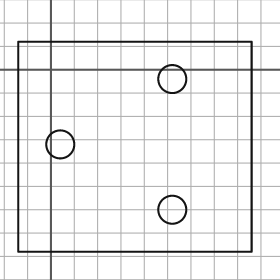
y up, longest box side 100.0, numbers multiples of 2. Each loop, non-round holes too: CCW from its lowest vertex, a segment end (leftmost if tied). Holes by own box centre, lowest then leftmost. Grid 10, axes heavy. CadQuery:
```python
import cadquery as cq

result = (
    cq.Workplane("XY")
    .moveTo(-14.0, -78.0)
    .lineTo(86.0, -78.0)
    .lineTo(86.0, 12.0)
    .lineTo(-14.0, 12.0)
    .close()
    .moveTo(52.0, -60.0)
    .circle(6.0)
    .moveTo(4.0, -32.0)
    .circle(6.0)
    .moveTo(52.0, -4.0)
    .circle(6.0)
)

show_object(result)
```